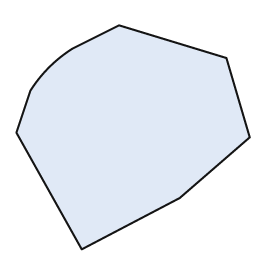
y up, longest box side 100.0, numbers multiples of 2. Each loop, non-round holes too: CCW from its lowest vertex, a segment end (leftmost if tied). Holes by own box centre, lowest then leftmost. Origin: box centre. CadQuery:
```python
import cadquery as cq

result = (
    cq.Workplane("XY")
    .moveTo(-22.0, -48.0)
    .lineTo(20.0, -26.0)
    .lineTo(50.0, 0.0)
    .lineTo(40.0, 34.0)
    .lineTo(-6.0, 48.0)
    .lineTo(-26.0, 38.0)
    .threePointArc((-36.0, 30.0), (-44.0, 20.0))
    .lineTo(-50.0, 2.0)
    .close()
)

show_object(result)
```